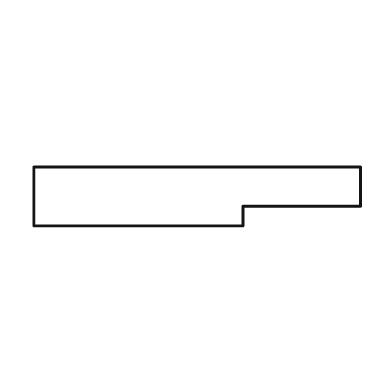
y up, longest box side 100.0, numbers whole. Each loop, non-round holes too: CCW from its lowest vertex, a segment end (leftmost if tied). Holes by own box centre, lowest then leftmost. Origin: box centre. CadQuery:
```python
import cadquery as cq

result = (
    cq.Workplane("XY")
    .moveTo(-50.0, -9.0)
    .lineTo(14.0, -9.0)
    .lineTo(14.0, -3.0)
    .lineTo(50.0, -3.0)
    .lineTo(50.0, 9.0)
    .lineTo(-50.0, 9.0)
    .close()
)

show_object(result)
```